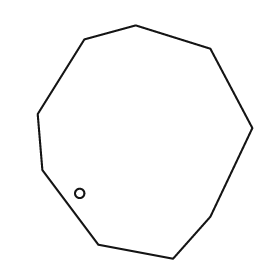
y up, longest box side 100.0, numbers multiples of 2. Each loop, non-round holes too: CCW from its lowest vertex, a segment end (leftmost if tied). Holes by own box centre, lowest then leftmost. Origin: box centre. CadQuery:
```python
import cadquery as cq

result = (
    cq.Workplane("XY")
    .moveTo(12.0, -50.0)
    .lineTo(28.0, -32.0)
    .lineTo(46.0, 6.0)
    .lineTo(28.0, 40.0)
    .lineTo(-4.0, 50.0)
    .lineTo(-26.0, 44.0)
    .lineTo(-46.0, 12.0)
    .lineTo(-44.0, -12.0)
    .lineTo(-20.0, -44.0)
    .close()
    .moveTo(-28.0, -22.0)
    .circle(2.0)
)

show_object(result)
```